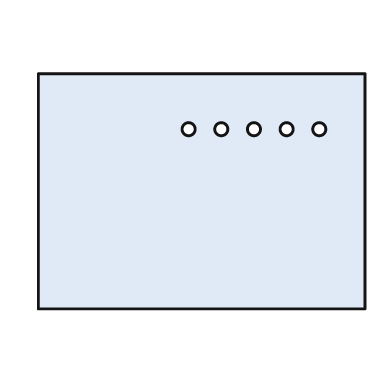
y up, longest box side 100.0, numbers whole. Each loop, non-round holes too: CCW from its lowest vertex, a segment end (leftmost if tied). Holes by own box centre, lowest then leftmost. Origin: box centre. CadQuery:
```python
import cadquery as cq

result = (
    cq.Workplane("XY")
    .moveTo(-50.0, -36.0)
    .lineTo(50.0, -36.0)
    .lineTo(50.0, 36.0)
    .lineTo(-50.0, 36.0)
    .close()
    .moveTo(-4.0, 19.0)
    .circle(2.0)
    .moveTo(6.0, 19.0)
    .circle(2.0)
    .moveTo(16.0, 19.0)
    .circle(2.0)
    .moveTo(26.0, 19.0)
    .circle(2.0)
    .moveTo(36.0, 19.0)
    .circle(2.0)
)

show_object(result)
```